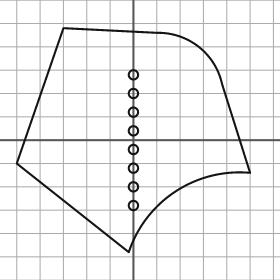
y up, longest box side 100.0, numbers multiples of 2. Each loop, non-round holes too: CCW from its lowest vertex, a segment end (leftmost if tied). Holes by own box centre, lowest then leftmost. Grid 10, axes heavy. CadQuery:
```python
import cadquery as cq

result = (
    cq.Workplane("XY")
    .moveTo(-2.0, -48.0)
    .threePointArc((18.0, -22.0), (50.0, -14.0))
    .lineTo(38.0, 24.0)
    .threePointArc((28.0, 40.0), (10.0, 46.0))
    .lineTo(-30.0, 48.0)
    .lineTo(-50.0, -10.0)
    .close()
    .moveTo(0.0, -28.0)
    .circle(2.0)
    .moveTo(0.0, -20.0)
    .circle(2.0)
    .moveTo(0.0, -12.0)
    .circle(2.0)
    .moveTo(0.0, -4.0)
    .circle(2.0)
    .moveTo(0.0, 4.0)
    .circle(2.0)
    .moveTo(0.0, 12.0)
    .circle(2.0)
    .moveTo(0.0, 20.0)
    .circle(2.0)
    .moveTo(0.0, 28.0)
    .circle(2.0)
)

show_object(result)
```